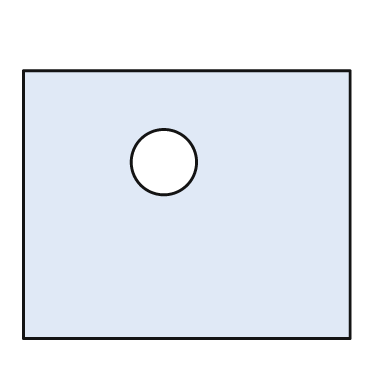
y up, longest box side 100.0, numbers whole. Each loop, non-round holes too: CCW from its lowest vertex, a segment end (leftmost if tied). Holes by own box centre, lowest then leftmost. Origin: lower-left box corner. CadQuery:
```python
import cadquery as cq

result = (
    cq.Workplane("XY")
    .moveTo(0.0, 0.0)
    .lineTo(100.0, 0.0)
    .lineTo(100.0, 82.0)
    .lineTo(0.0, 82.0)
    .close()
    .moveTo(43.0, 54.0)
    .circle(10.0)
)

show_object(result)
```